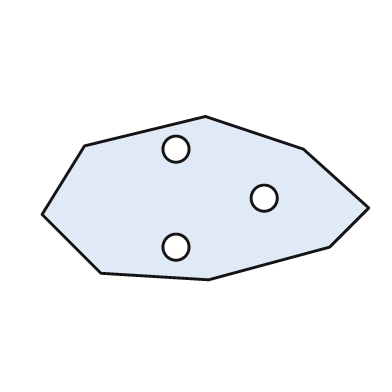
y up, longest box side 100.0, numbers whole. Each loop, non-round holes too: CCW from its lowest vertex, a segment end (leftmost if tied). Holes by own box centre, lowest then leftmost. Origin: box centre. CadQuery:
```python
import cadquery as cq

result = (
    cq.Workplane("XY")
    .moveTo(1.0, -25.0)
    .lineTo(38.0, -15.0)
    .lineTo(50.0, -3.0)
    .lineTo(30.0, 15.0)
    .lineTo(0.0, 25.0)
    .lineTo(-37.0, 16.0)
    .lineTo(-50.0, -5.0)
    .lineTo(-32.0, -23.0)
    .close()
    .moveTo(-9.0, -15.0)
    .circle(4.0)
    .moveTo(18.0, 0.0)
    .circle(4.0)
    .moveTo(-9.0, 15.0)
    .circle(4.0)
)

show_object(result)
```